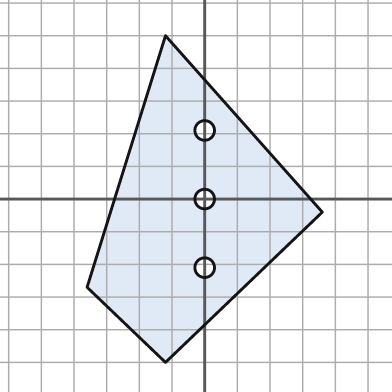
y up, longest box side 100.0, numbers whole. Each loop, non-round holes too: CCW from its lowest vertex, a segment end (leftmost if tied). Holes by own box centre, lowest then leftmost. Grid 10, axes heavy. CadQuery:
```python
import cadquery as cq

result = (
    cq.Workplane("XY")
    .moveTo(-12.0, -50.0)
    .lineTo(36.0, -4.0)
    .lineTo(-12.0, 50.0)
    .lineTo(-36.0, -27.0)
    .close()
    .moveTo(0.0, -21.0)
    .circle(3.0)
    .moveTo(0.0, 0.0)
    .circle(3.0)
    .moveTo(0.0, 21.0)
    .circle(3.0)
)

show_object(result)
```